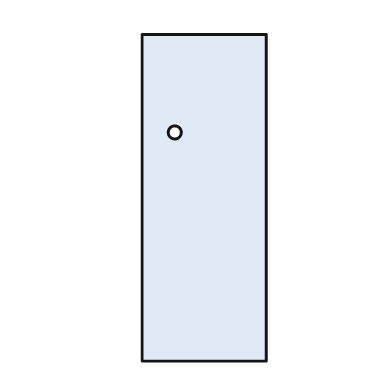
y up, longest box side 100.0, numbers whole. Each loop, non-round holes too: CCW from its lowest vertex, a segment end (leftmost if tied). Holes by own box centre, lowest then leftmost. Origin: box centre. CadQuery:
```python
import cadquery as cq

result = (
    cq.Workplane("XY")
    .moveTo(-19.0, -50.0)
    .lineTo(19.0, -50.0)
    .lineTo(19.0, 50.0)
    .lineTo(-19.0, 50.0)
    .close()
    .moveTo(-9.0, 20.0)
    .circle(2.0)
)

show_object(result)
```